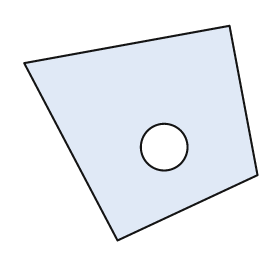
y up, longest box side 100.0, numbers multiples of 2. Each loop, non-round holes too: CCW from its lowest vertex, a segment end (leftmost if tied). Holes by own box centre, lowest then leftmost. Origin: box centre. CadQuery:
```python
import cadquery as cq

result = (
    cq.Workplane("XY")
    .moveTo(-10.0, -46.0)
    .lineTo(50.0, -18.0)
    .lineTo(38.0, 46.0)
    .lineTo(-50.0, 30.0)
    .close()
    .moveTo(10.0, -6.0)
    .circle(10.0)
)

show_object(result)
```